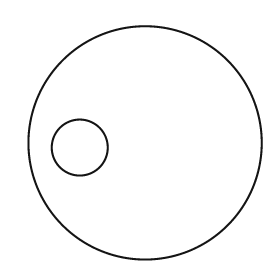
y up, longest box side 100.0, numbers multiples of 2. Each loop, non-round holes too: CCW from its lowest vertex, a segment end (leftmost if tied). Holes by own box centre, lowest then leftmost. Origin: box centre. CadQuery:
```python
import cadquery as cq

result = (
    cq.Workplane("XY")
    .moveTo(0.0, 0.0)
    .circle(50.0)
    .moveTo(-28.0, -2.0)
    .circle(12.0)
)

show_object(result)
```